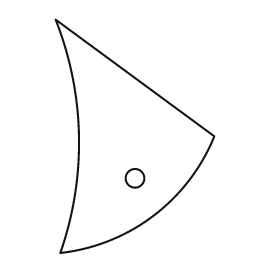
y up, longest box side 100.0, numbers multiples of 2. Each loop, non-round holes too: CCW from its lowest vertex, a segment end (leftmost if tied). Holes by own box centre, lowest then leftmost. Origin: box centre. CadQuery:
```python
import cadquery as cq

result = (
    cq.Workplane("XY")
    .moveTo(-32.0, -50.0)
    .threePointArc((8.0, -34.0), (34.0, 0.0))
    .lineTo(-34.0, 50.0)
    .threePointArc((-24.0, 0.0), (-32.0, -50.0))
    .close()
    .moveTo(0.0, -18.0)
    .circle(4.0)
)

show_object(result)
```